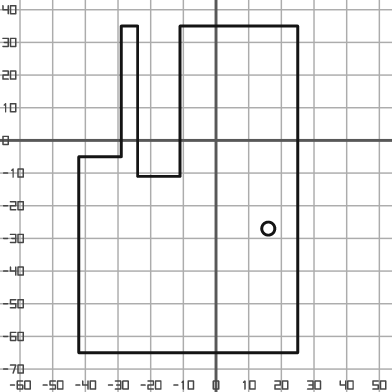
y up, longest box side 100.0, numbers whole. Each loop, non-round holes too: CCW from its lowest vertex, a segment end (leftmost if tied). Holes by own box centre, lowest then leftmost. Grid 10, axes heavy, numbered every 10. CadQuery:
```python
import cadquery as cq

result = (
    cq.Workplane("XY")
    .moveTo(-42.0, -65.0)
    .lineTo(25.0, -65.0)
    .lineTo(25.0, 35.0)
    .lineTo(-11.0, 35.0)
    .lineTo(-11.0, -11.0)
    .lineTo(-24.0, -11.0)
    .lineTo(-24.0, 35.0)
    .lineTo(-29.0, 35.0)
    .lineTo(-29.0, -5.0)
    .lineTo(-42.0, -5.0)
    .close()
    .moveTo(16.0, -27.0)
    .circle(2.0)
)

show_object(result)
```